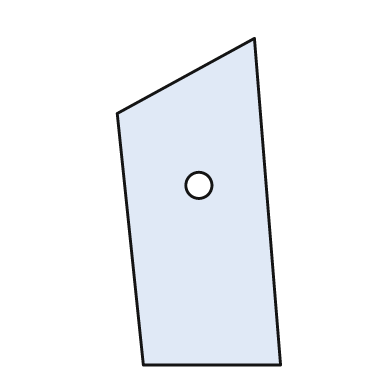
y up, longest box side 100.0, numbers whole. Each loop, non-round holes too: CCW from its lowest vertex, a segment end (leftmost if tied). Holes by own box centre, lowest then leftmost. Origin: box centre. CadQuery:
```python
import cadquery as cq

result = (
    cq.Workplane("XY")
    .moveTo(-17.0, -50.0)
    .lineTo(25.0, -50.0)
    .lineTo(17.0, 50.0)
    .lineTo(-25.0, 27.0)
    .close()
    .moveTo(0.0, 5.0)
    .circle(4.0)
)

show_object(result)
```